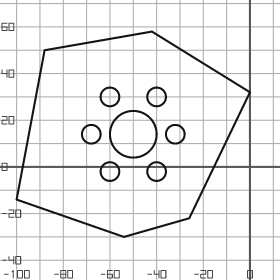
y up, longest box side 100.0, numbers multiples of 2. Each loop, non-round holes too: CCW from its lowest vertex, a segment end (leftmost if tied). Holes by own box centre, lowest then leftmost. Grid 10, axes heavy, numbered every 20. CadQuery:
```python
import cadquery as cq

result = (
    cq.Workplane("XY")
    .moveTo(-54.0, -30.0)
    .lineTo(-26.0, -22.0)
    .lineTo(0.0, 32.0)
    .lineTo(-42.0, 58.0)
    .lineTo(-88.0, 50.0)
    .lineTo(-100.0, -14.0)
    .close()
    .moveTo(-60.0, -2.0)
    .circle(4.0)
    .moveTo(-40.0, -2.0)
    .circle(4.0)
    .moveTo(-68.0, 14.0)
    .circle(4.0)
    .moveTo(-50.0, 14.0)
    .circle(10.0)
    .moveTo(-32.0, 14.0)
    .circle(4.0)
    .moveTo(-60.0, 30.0)
    .circle(4.0)
    .moveTo(-40.0, 30.0)
    .circle(4.0)
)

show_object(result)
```